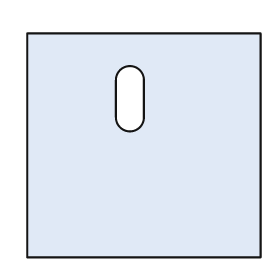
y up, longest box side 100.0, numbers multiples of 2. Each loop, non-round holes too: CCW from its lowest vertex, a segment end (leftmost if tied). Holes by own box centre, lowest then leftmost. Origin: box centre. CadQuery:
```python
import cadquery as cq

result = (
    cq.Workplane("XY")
    .moveTo(-50.0, -48.0)
    .lineTo(50.0, -48.0)
    .lineTo(50.0, 48.0)
    .lineTo(-50.0, 48.0)
    .close()
    .moveTo(-12.0, 12.0)
    .threePointArc((-6.0, 6.0), (0.0, 12.0))
    .lineTo(0.0, 28.0)
    .threePointArc((-6.0, 34.0), (-12.0, 28.0))
    .close()
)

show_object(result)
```